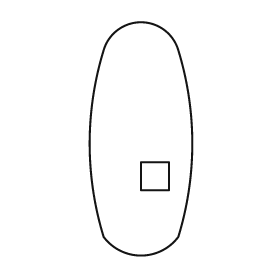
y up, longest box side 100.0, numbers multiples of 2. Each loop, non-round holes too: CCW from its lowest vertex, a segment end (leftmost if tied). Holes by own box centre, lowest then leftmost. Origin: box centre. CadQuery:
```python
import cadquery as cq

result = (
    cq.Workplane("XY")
    .moveTo(-16.0, -42.0)
    .threePointArc((0.0, -50.0), (16.0, -42.0))
    .threePointArc((22.0, -2.0), (16.0, 38.0))
    .threePointArc((0.0, 50.0), (-16.0, 38.0))
    .threePointArc((-22.0, -2.0), (-16.0, -42.0))
    .close()
    .moveTo(0.0, -22.0)
    .lineTo(12.0, -22.0)
    .lineTo(12.0, -10.0)
    .lineTo(0.0, -10.0)
    .close()
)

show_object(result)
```